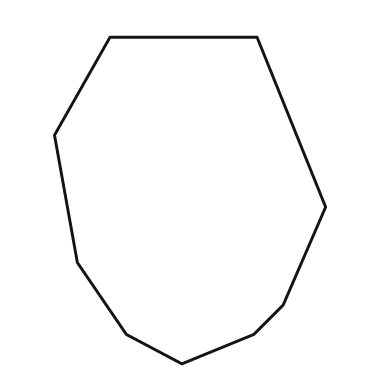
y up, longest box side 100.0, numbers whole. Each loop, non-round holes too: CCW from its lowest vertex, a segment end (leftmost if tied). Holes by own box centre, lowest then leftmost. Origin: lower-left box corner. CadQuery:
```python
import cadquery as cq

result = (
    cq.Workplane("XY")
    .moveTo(39.0, 0.0)
    .lineTo(61.0, 9.0)
    .lineTo(70.0, 18.0)
    .lineTo(83.0, 48.0)
    .lineTo(62.0, 100.0)
    .lineTo(17.0, 100.0)
    .lineTo(0.0, 70.0)
    .lineTo(7.0, 31.0)
    .lineTo(22.0, 9.0)
    .close()
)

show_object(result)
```